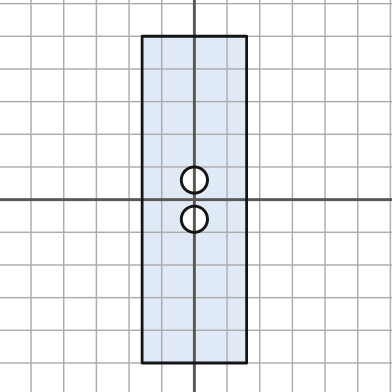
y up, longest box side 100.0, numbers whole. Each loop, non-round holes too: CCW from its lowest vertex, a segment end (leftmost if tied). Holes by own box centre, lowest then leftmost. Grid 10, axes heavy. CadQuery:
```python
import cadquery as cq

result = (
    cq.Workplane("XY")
    .moveTo(-16.0, -50.0)
    .lineTo(16.0, -50.0)
    .lineTo(16.0, 50.0)
    .lineTo(-16.0, 50.0)
    .close()
    .moveTo(0.0, -6.0)
    .circle(4.0)
    .moveTo(0.0, 6.0)
    .circle(4.0)
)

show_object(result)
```